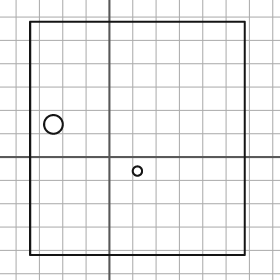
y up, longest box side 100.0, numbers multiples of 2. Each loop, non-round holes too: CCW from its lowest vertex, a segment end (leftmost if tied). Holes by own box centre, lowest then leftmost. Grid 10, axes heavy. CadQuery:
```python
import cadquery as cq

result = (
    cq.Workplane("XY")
    .moveTo(-34.0, -42.0)
    .lineTo(58.0, -42.0)
    .lineTo(58.0, 58.0)
    .lineTo(-34.0, 58.0)
    .close()
    .moveTo(12.0, -6.0)
    .circle(2.0)
    .moveTo(-24.0, 14.0)
    .circle(4.0)
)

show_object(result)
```